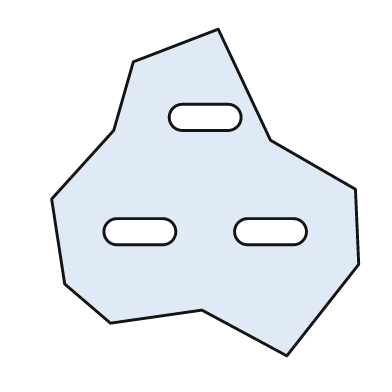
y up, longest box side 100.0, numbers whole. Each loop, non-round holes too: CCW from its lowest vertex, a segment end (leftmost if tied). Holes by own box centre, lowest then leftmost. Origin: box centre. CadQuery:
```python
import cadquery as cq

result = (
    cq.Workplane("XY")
    .moveTo(25.0, -50.0)
    .lineTo(47.0, -22.0)
    .lineTo(46.0, 1.0)
    .lineTo(20.0, 16.0)
    .lineTo(4.0, 50.0)
    .lineTo(-22.0, 40.0)
    .lineTo(-28.0, 19.0)
    .lineTo(-47.0, -2.0)
    .lineTo(-43.0, -28.0)
    .lineTo(-29.0, -40.0)
    .lineTo(-1.0, -36.0)
    .close()
    .moveTo(-27.0, -16.0)
    .lineTo(-13.0, -16.0)
    .threePointArc((-9.0, -12.0), (-13.0, -8.0))
    .lineTo(-27.0, -8.0)
    .threePointArc((-31.0, -12.0), (-27.0, -16.0))
    .close()
    .moveTo(13.0, -16.0)
    .lineTo(27.0, -16.0)
    .threePointArc((31.0, -12.0), (27.0, -8.0))
    .lineTo(13.0, -8.0)
    .threePointArc((9.0, -12.0), (13.0, -16.0))
    .close()
    .moveTo(-7.0, 19.0)
    .lineTo(7.0, 19.0)
    .threePointArc((11.0, 23.0), (7.0, 27.0))
    .lineTo(-7.0, 27.0)
    .threePointArc((-11.0, 23.0), (-7.0, 19.0))
    .close()
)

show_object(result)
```